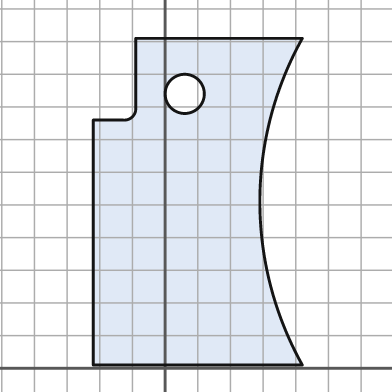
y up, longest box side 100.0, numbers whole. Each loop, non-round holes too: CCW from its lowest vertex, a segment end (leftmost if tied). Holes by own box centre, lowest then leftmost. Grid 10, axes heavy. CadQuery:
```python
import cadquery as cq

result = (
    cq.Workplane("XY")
    .moveTo(-22.0, 1.0)
    .lineTo(42.0, 1.0)
    .threePointArc((29.0, 51.0), (42.0, 101.0))
    .lineTo(-9.0, 101.0)
    .lineTo(-9.0, 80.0)
    .threePointArc((-10.0, 77.0), (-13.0, 76.0))
    .lineTo(-22.0, 76.0)
    .close()
    .moveTo(6.0, 84.0)
    .circle(6.0)
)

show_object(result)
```